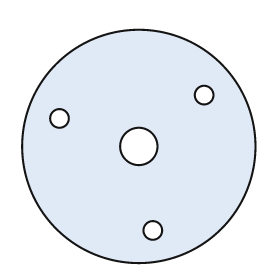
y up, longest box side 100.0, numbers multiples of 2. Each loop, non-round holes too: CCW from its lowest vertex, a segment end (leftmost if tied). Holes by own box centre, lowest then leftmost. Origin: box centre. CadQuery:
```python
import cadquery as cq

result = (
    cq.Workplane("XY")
    .moveTo(0.0, 0.0)
    .circle(50.0)
    .moveTo(6.0, -36.0)
    .circle(4.0)
    .moveTo(0.0, 0.0)
    .circle(8.0)
    .moveTo(-34.0, 12.0)
    .circle(4.0)
    .moveTo(28.0, 22.0)
    .circle(4.0)
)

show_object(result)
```